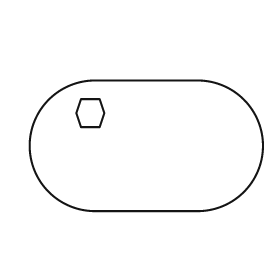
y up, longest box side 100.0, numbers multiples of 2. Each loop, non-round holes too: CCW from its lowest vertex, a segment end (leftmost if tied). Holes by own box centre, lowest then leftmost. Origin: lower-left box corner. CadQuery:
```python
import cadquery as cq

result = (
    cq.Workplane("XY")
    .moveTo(28.0, 0.0)
    .lineTo(72.0, 0.0)
    .threePointArc((100.0, 28.0), (72.0, 56.0))
    .lineTo(28.0, 56.0)
    .threePointArc((0.0, 28.0), (28.0, 0.0))
    .close()
    .moveTo(22.0, 36.0)
    .lineTo(30.0, 36.0)
    .lineTo(32.0, 42.0)
    .lineTo(30.0, 48.0)
    .lineTo(22.0, 48.0)
    .lineTo(20.0, 42.0)
    .close()
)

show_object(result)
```